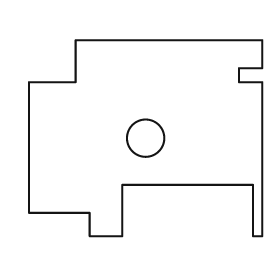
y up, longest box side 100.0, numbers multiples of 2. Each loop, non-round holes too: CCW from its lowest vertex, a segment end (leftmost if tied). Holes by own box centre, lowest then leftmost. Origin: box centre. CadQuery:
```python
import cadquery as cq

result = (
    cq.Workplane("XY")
    .moveTo(-24.0, -42.0)
    .lineTo(-10.0, -42.0)
    .lineTo(-10.0, -20.0)
    .lineTo(46.0, -20.0)
    .lineTo(46.0, -42.0)
    .lineTo(50.0, -42.0)
    .lineTo(50.0, 24.0)
    .lineTo(40.0, 24.0)
    .lineTo(40.0, 30.0)
    .lineTo(50.0, 30.0)
    .lineTo(50.0, 42.0)
    .lineTo(-30.0, 42.0)
    .lineTo(-30.0, 24.0)
    .lineTo(-50.0, 24.0)
    .lineTo(-50.0, -32.0)
    .lineTo(-24.0, -32.0)
    .close()
    .moveTo(0.0, 0.0)
    .circle(8.0)
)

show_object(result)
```